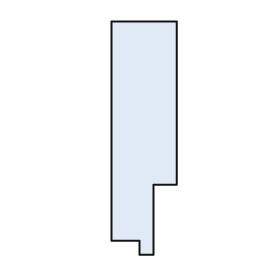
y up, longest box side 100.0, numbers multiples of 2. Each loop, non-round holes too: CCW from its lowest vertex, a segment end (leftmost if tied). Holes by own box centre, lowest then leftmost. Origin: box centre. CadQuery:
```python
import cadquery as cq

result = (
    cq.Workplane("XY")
    .moveTo(-2.0, -50.0)
    .lineTo(4.0, -50.0)
    .lineTo(4.0, -20.0)
    .lineTo(14.0, -20.0)
    .lineTo(14.0, 50.0)
    .lineTo(-14.0, 50.0)
    .lineTo(-14.0, -44.0)
    .lineTo(-2.0, -44.0)
    .close()
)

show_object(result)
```